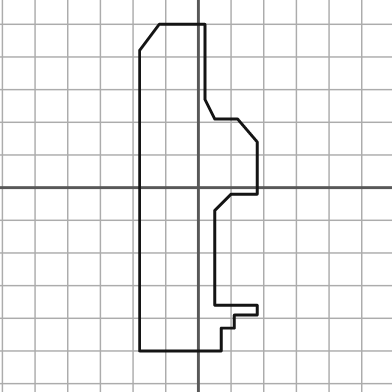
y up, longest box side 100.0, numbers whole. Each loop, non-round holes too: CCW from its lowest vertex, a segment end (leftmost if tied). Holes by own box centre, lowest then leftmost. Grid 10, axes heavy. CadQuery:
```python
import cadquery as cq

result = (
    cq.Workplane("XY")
    .moveTo(-18.0, -50.0)
    .lineTo(7.0, -50.0)
    .lineTo(7.0, -43.0)
    .lineTo(11.0, -43.0)
    .lineTo(11.0, -39.0)
    .lineTo(18.0, -39.0)
    .lineTo(18.0, -36.0)
    .lineTo(5.0, -36.0)
    .lineTo(5.0, -7.0)
    .lineTo(10.0, -2.0)
    .lineTo(18.0, -2.0)
    .lineTo(18.0, 14.0)
    .lineTo(12.0, 21.0)
    .lineTo(5.0, 21.0)
    .lineTo(2.0, 27.0)
    .lineTo(2.0, 50.0)
    .lineTo(-12.0, 50.0)
    .lineTo(-18.0, 42.0)
    .close()
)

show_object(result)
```